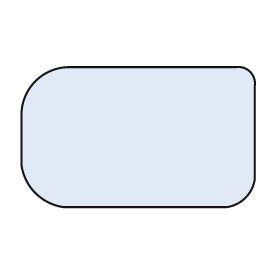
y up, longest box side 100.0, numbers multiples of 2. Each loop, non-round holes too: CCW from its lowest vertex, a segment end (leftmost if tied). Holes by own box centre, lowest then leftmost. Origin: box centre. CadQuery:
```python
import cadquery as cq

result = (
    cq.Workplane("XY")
    .moveTo(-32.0, -30.0)
    .lineTo(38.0, -30.0)
    .threePointArc((46.0, -26.0), (50.0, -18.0))
    .lineTo(50.0, 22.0)
    .threePointArc((48.0, 28.0), (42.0, 30.0))
    .lineTo(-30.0, 30.0)
    .threePointArc((-44.0, 24.0), (-50.0, 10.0))
    .lineTo(-50.0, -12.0)
    .threePointArc((-44.0, -24.0), (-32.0, -30.0))
    .close()
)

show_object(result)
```